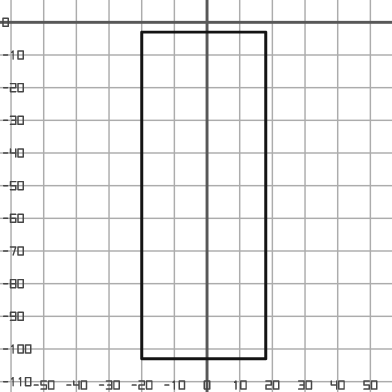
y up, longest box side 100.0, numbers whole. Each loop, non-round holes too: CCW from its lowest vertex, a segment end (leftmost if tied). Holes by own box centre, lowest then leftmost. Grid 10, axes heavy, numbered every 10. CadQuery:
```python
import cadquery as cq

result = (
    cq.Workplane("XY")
    .moveTo(-20.0, -103.0)
    .lineTo(18.0, -103.0)
    .lineTo(18.0, -3.0)
    .lineTo(-20.0, -3.0)
    .close()
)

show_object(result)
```